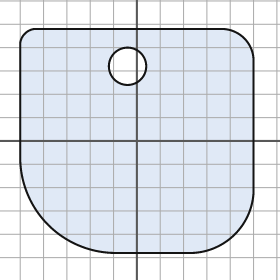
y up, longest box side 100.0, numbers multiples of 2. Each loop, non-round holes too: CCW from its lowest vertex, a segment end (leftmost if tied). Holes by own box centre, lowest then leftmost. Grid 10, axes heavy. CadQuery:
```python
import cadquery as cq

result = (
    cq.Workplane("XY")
    .moveTo(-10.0, -48.0)
    .lineTo(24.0, -48.0)
    .threePointArc((42.0, -40.0), (50.0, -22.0))
    .lineTo(50.0, 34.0)
    .threePointArc((46.0, 44.0), (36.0, 48.0))
    .lineTo(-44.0, 48.0)
    .threePointArc((-48.0, 46.0), (-50.0, 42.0))
    .lineTo(-50.0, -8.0)
    .threePointArc((-38.0, -36.0), (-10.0, -48.0))
    .close()
    .moveTo(-4.0, 32.0)
    .circle(8.0)
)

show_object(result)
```